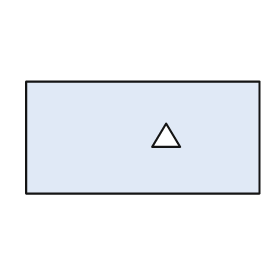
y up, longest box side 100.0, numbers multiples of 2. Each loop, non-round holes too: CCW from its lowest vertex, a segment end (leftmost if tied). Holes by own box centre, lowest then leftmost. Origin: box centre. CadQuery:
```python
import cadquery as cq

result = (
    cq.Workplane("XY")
    .moveTo(-50.0, -24.0)
    .lineTo(50.0, -24.0)
    .lineTo(50.0, 24.0)
    .lineTo(-50.0, 24.0)
    .close()
    .moveTo(4.0, -4.0)
    .lineTo(16.0, -4.0)
    .lineTo(10.0, 6.0)
    .close()
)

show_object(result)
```